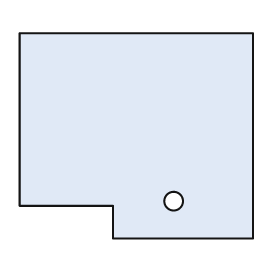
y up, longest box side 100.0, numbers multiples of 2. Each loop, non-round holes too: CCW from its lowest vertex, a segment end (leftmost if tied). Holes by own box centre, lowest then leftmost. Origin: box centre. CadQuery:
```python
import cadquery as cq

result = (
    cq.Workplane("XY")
    .moveTo(-10.0, -44.0)
    .lineTo(50.0, -44.0)
    .lineTo(50.0, 44.0)
    .lineTo(-50.0, 44.0)
    .lineTo(-50.0, -30.0)
    .lineTo(-10.0, -30.0)
    .close()
    .moveTo(16.0, -28.0)
    .circle(4.0)
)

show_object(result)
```